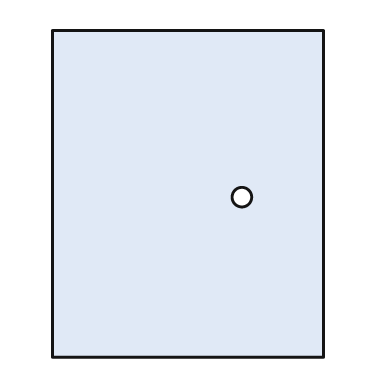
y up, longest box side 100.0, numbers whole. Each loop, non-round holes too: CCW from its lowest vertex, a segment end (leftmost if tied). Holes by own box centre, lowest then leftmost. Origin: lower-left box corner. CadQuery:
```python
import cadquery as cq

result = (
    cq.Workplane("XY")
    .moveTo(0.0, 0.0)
    .lineTo(83.0, 0.0)
    .lineTo(83.0, 100.0)
    .lineTo(0.0, 100.0)
    .close()
    .moveTo(58.0, 49.0)
    .circle(3.0)
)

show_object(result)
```